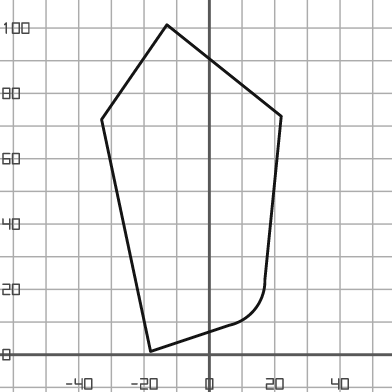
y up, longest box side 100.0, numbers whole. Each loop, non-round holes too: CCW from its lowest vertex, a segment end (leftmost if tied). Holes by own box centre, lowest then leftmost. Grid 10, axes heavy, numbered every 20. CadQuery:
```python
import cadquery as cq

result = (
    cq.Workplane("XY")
    .moveTo(-18.0, 1.0)
    .lineTo(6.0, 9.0)
    .threePointArc((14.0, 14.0), (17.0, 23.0))
    .lineTo(22.0, 73.0)
    .lineTo(-13.0, 101.0)
    .lineTo(-33.0, 72.0)
    .close()
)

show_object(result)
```